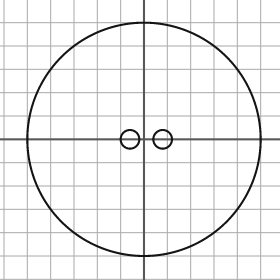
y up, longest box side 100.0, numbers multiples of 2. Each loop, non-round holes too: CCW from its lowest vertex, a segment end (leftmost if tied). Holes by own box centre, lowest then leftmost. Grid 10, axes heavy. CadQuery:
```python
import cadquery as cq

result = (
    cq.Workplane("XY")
    .moveTo(0.0, 0.0)
    .circle(50.0)
    .moveTo(-6.0, 0.0)
    .circle(4.0)
    .moveTo(8.0, 0.0)
    .circle(4.0)
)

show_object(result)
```